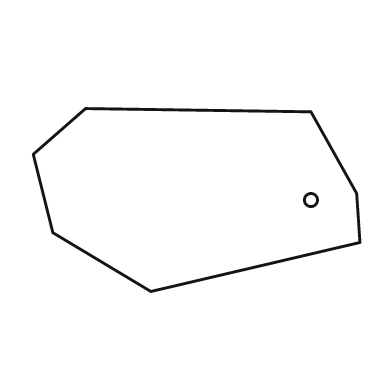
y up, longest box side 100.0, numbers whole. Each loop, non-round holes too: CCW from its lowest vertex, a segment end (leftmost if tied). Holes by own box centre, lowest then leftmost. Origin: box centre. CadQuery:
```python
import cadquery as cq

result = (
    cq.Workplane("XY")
    .moveTo(-14.0, -28.0)
    .lineTo(50.0, -13.0)
    .lineTo(49.0, 2.0)
    .lineTo(35.0, 27.0)
    .lineTo(-34.0, 28.0)
    .lineTo(-50.0, 14.0)
    .lineTo(-44.0, -10.0)
    .close()
    .moveTo(35.0, 0.0)
    .circle(2.0)
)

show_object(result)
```